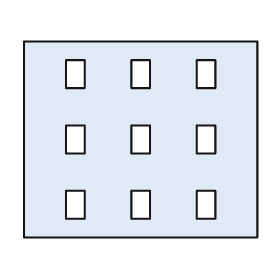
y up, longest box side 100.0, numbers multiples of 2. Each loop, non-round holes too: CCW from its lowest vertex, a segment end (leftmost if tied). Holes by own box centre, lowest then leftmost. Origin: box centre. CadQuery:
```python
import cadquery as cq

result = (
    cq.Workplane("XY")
    .moveTo(-50.0, -42.0)
    .lineTo(50.0, -42.0)
    .lineTo(50.0, 42.0)
    .lineTo(-50.0, 42.0)
    .close()
    .moveTo(-32.0, -34.0)
    .lineTo(-24.0, -34.0)
    .lineTo(-24.0, -22.0)
    .lineTo(-32.0, -22.0)
    .close()
    .moveTo(-4.0, -34.0)
    .lineTo(4.0, -34.0)
    .lineTo(4.0, -22.0)
    .lineTo(-4.0, -22.0)
    .close()
    .moveTo(24.0, -34.0)
    .lineTo(32.0, -34.0)
    .lineTo(32.0, -22.0)
    .lineTo(24.0, -22.0)
    .close()
    .moveTo(-32.0, -6.0)
    .lineTo(-24.0, -6.0)
    .lineTo(-24.0, 6.0)
    .lineTo(-32.0, 6.0)
    .close()
    .moveTo(-4.0, -6.0)
    .lineTo(4.0, -6.0)
    .lineTo(4.0, 6.0)
    .lineTo(-4.0, 6.0)
    .close()
    .moveTo(24.0, -6.0)
    .lineTo(32.0, -6.0)
    .lineTo(32.0, 6.0)
    .lineTo(24.0, 6.0)
    .close()
    .moveTo(-32.0, 22.0)
    .lineTo(-24.0, 22.0)
    .lineTo(-24.0, 34.0)
    .lineTo(-32.0, 34.0)
    .close()
    .moveTo(-4.0, 22.0)
    .lineTo(4.0, 22.0)
    .lineTo(4.0, 34.0)
    .lineTo(-4.0, 34.0)
    .close()
    .moveTo(24.0, 22.0)
    .lineTo(32.0, 22.0)
    .lineTo(32.0, 34.0)
    .lineTo(24.0, 34.0)
    .close()
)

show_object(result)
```